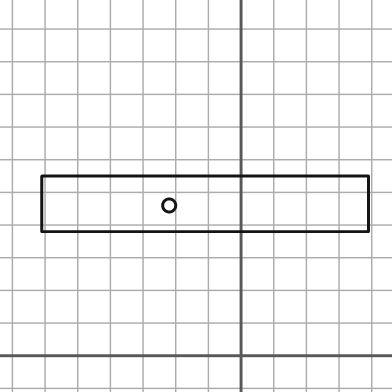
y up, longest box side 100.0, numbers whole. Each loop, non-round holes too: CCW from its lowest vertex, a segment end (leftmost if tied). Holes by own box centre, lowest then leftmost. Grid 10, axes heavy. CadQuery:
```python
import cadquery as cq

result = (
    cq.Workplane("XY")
    .moveTo(-61.0, 38.0)
    .lineTo(39.0, 38.0)
    .lineTo(39.0, 55.0)
    .lineTo(-61.0, 55.0)
    .close()
    .moveTo(-22.0, 46.0)
    .circle(2.0)
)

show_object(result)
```